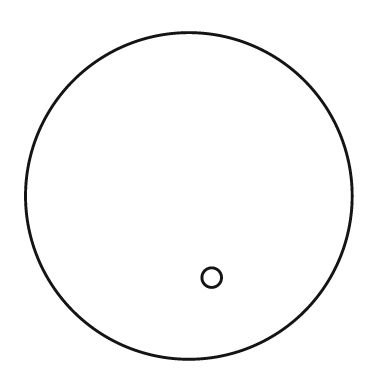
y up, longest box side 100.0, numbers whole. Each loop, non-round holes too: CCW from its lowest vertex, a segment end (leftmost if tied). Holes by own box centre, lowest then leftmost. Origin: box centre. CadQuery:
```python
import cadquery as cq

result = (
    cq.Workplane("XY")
    .moveTo(0.0, 0.0)
    .circle(50.0)
    .moveTo(7.0, -25.0)
    .circle(3.0)
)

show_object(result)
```